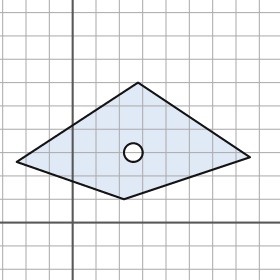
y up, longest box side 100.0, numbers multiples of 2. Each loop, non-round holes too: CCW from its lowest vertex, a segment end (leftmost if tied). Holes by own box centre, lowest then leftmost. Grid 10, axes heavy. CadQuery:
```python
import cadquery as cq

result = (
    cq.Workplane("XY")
    .moveTo(22.0, 10.0)
    .lineTo(76.0, 28.0)
    .lineTo(28.0, 60.0)
    .lineTo(-24.0, 26.0)
    .close()
    .moveTo(26.0, 30.0)
    .circle(4.0)
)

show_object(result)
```